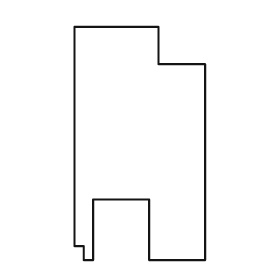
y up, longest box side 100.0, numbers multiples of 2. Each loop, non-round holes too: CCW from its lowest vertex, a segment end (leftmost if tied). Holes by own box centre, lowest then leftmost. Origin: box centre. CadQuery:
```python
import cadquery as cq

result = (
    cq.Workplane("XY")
    .moveTo(-24.0, -50.0)
    .lineTo(-20.0, -50.0)
    .lineTo(-20.0, -24.0)
    .lineTo(4.0, -24.0)
    .lineTo(4.0, -50.0)
    .lineTo(28.0, -50.0)
    .lineTo(28.0, 34.0)
    .lineTo(8.0, 34.0)
    .lineTo(8.0, 50.0)
    .lineTo(-28.0, 50.0)
    .lineTo(-28.0, -44.0)
    .lineTo(-24.0, -44.0)
    .close()
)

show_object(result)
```